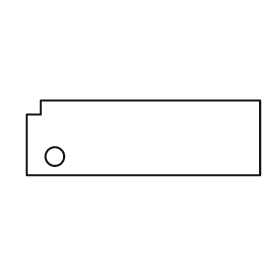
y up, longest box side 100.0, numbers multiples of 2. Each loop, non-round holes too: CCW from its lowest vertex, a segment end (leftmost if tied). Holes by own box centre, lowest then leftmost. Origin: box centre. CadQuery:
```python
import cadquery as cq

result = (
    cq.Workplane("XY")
    .moveTo(-50.0, -16.0)
    .lineTo(50.0, -16.0)
    .lineTo(50.0, 16.0)
    .lineTo(-44.0, 16.0)
    .lineTo(-44.0, 10.0)
    .lineTo(-50.0, 10.0)
    .close()
    .moveTo(-38.0, -8.0)
    .circle(4.0)
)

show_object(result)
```